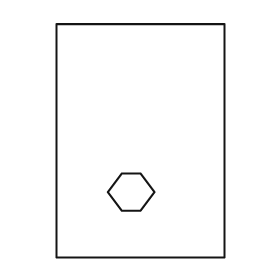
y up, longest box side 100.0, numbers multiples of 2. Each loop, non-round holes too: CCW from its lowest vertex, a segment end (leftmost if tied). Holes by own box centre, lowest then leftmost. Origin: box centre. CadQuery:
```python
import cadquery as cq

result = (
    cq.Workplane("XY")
    .moveTo(-36.0, -50.0)
    .lineTo(36.0, -50.0)
    .lineTo(36.0, 50.0)
    .lineTo(-36.0, 50.0)
    .close()
    .moveTo(-8.0, -30.0)
    .lineTo(0.0, -30.0)
    .lineTo(6.0, -22.0)
    .lineTo(0.0, -14.0)
    .lineTo(-8.0, -14.0)
    .lineTo(-14.0, -22.0)
    .close()
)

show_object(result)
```